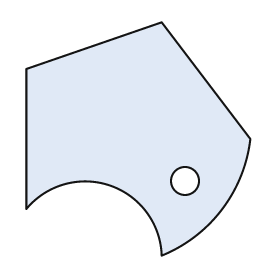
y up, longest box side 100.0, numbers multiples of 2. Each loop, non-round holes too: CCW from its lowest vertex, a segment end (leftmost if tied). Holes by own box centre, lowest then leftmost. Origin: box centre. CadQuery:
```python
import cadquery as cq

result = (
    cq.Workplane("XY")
    .moveTo(10.0, -50.0)
    .threePointArc((36.0, -30.0), (48.0, 0.0))
    .lineTo(10.0, 50.0)
    .lineTo(-48.0, 30.0)
    .lineTo(-48.0, -30.0)
    .threePointArc((-12.0, -20.0), (10.0, -50.0))
    .close()
    .moveTo(20.0, -18.0)
    .circle(6.0)
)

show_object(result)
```